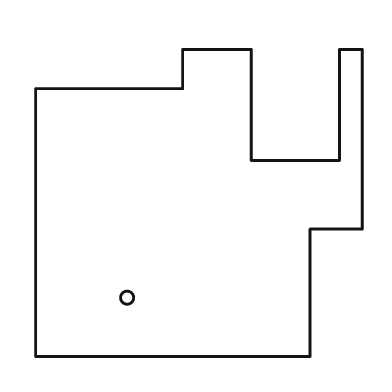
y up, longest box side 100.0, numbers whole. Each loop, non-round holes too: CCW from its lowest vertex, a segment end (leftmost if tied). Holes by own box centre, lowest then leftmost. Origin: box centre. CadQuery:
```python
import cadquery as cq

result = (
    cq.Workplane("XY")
    .moveTo(-50.0, -47.0)
    .lineTo(34.0, -47.0)
    .lineTo(34.0, -8.0)
    .lineTo(50.0, -8.0)
    .lineTo(50.0, 47.0)
    .lineTo(43.0, 47.0)
    .lineTo(43.0, 13.0)
    .lineTo(16.0, 13.0)
    .lineTo(16.0, 47.0)
    .lineTo(-5.0, 47.0)
    .lineTo(-5.0, 35.0)
    .lineTo(-50.0, 35.0)
    .close()
    .moveTo(-22.0, -29.0)
    .circle(2.0)
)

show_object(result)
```